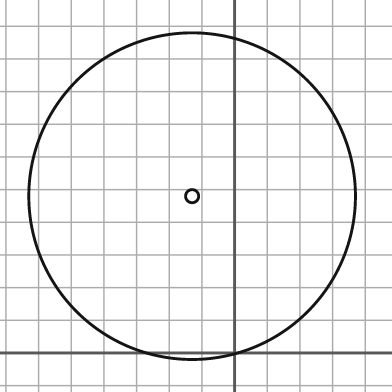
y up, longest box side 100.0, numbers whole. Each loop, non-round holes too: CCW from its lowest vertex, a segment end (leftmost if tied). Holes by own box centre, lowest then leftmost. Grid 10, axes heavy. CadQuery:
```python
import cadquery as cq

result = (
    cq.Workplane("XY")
    .moveTo(-13.0, 48.0)
    .circle(50.0)
    .moveTo(-13.0, 48.0)
    .circle(2.0)
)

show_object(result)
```